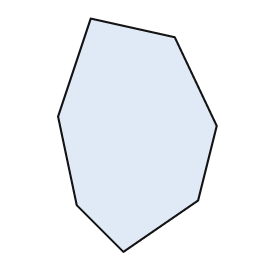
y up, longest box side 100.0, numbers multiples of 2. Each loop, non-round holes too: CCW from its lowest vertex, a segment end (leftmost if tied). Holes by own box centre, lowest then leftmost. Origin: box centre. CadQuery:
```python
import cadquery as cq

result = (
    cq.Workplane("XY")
    .moveTo(-6.0, -50.0)
    .lineTo(26.0, -28.0)
    .lineTo(34.0, 4.0)
    .lineTo(16.0, 42.0)
    .lineTo(-20.0, 50.0)
    .lineTo(-34.0, 8.0)
    .lineTo(-26.0, -30.0)
    .close()
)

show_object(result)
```